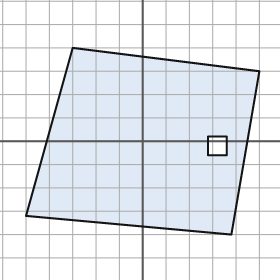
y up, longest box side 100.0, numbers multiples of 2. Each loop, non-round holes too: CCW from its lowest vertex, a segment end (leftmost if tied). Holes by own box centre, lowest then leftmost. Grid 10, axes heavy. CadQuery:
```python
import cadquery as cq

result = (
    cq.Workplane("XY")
    .moveTo(38.0, -40.0)
    .lineTo(50.0, 30.0)
    .lineTo(-30.0, 40.0)
    .lineTo(-50.0, -32.0)
    .close()
    .moveTo(28.0, -6.0)
    .lineTo(36.0, -6.0)
    .lineTo(36.0, 2.0)
    .lineTo(28.0, 2.0)
    .close()
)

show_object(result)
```